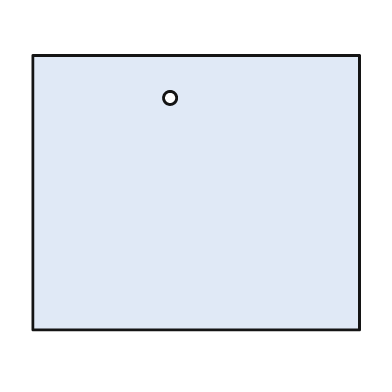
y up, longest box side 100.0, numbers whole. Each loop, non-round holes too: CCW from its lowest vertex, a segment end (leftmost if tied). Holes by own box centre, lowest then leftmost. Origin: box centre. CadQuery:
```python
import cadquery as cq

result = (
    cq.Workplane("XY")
    .moveTo(-50.0, -42.0)
    .lineTo(50.0, -42.0)
    .lineTo(50.0, 42.0)
    .lineTo(-50.0, 42.0)
    .close()
    .moveTo(-8.0, 29.0)
    .circle(2.0)
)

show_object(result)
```